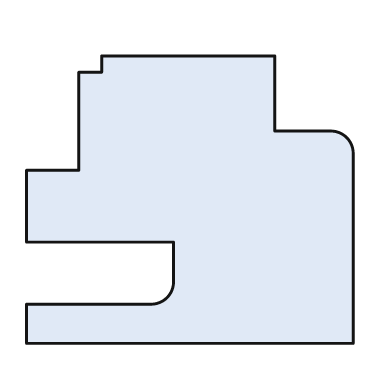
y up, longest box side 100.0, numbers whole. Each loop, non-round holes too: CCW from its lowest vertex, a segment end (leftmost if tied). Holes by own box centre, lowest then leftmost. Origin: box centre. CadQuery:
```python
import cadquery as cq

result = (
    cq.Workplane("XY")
    .moveTo(-50.0, -44.0)
    .lineTo(50.0, -44.0)
    .lineTo(50.0, 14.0)
    .threePointArc((48.0, 19.0), (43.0, 21.0))
    .lineTo(26.0, 21.0)
    .lineTo(26.0, 44.0)
    .lineTo(-27.0, 44.0)
    .lineTo(-27.0, 39.0)
    .lineTo(-34.0, 39.0)
    .lineTo(-34.0, 9.0)
    .lineTo(-50.0, 9.0)
    .lineTo(-50.0, -13.0)
    .lineTo(-5.0, -13.0)
    .lineTo(-5.0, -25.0)
    .threePointArc((-7.0, -30.0), (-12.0, -32.0))
    .lineTo(-50.0, -32.0)
    .close()
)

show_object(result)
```